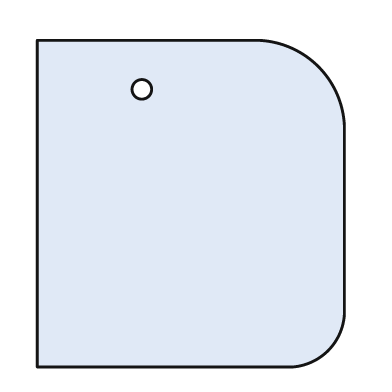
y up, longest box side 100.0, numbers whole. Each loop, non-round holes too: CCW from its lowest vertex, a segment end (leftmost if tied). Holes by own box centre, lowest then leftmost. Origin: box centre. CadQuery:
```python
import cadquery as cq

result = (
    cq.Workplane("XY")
    .moveTo(-47.0, -50.0)
    .lineTo(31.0, -50.0)
    .threePointArc((42.0, -45.0), (47.0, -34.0))
    .lineTo(47.0, 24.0)
    .threePointArc((39.0, 42.0), (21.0, 50.0))
    .lineTo(-47.0, 50.0)
    .close()
    .moveTo(-15.0, 35.0)
    .circle(3.0)
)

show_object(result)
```